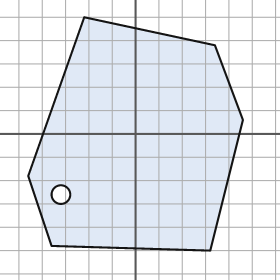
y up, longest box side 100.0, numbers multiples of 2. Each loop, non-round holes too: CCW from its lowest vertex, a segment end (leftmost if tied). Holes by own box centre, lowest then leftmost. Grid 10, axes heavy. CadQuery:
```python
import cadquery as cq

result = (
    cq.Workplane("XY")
    .moveTo(32.0, -50.0)
    .lineTo(46.0, 6.0)
    .lineTo(34.0, 38.0)
    .lineTo(-22.0, 50.0)
    .lineTo(-46.0, -18.0)
    .lineTo(-36.0, -48.0)
    .close()
    .moveTo(-32.0, -26.0)
    .circle(4.0)
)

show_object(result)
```